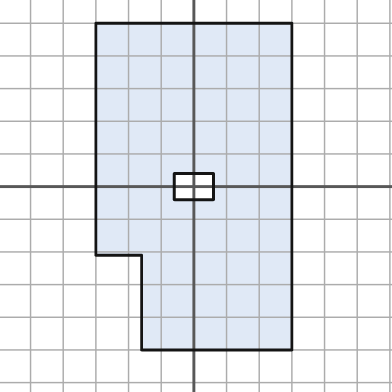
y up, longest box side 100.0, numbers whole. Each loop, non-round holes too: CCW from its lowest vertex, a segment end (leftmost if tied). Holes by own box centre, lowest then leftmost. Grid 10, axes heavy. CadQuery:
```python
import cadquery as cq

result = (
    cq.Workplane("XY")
    .moveTo(-16.0, -50.0)
    .lineTo(30.0, -50.0)
    .lineTo(30.0, 50.0)
    .lineTo(-30.0, 50.0)
    .lineTo(-30.0, -21.0)
    .lineTo(-16.0, -21.0)
    .close()
    .moveTo(-6.0, -4.0)
    .lineTo(6.0, -4.0)
    .lineTo(6.0, 4.0)
    .lineTo(-6.0, 4.0)
    .close()
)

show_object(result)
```